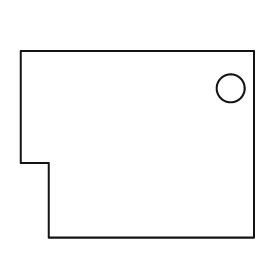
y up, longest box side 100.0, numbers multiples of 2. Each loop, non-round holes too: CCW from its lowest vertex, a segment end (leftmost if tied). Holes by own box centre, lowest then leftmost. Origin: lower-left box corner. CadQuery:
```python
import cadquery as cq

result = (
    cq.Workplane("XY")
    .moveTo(12.0, 0.0)
    .lineTo(100.0, 0.0)
    .lineTo(100.0, 80.0)
    .lineTo(0.0, 80.0)
    .lineTo(0.0, 32.0)
    .lineTo(12.0, 32.0)
    .close()
    .moveTo(90.0, 64.0)
    .circle(6.0)
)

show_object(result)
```